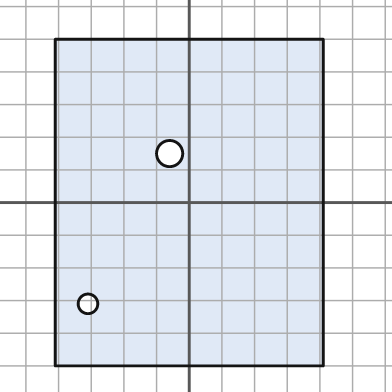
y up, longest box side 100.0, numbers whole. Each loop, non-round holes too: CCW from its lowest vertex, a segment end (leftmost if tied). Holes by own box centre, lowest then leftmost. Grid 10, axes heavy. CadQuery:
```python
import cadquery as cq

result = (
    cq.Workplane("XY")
    .moveTo(-41.0, -50.0)
    .lineTo(41.0, -50.0)
    .lineTo(41.0, 50.0)
    .lineTo(-41.0, 50.0)
    .close()
    .moveTo(-31.0, -31.0)
    .circle(3.0)
    .moveTo(-6.0, 15.0)
    .circle(4.0)
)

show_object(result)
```